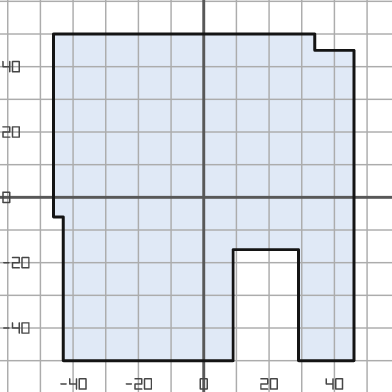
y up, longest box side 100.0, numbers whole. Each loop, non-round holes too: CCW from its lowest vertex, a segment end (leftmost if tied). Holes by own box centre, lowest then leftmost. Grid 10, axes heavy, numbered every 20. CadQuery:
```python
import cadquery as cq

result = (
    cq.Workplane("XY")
    .moveTo(-43.0, -50.0)
    .lineTo(9.0, -50.0)
    .lineTo(9.0, -16.0)
    .lineTo(29.0, -16.0)
    .lineTo(29.0, -50.0)
    .lineTo(46.0, -50.0)
    .lineTo(46.0, 45.0)
    .lineTo(34.0, 45.0)
    .lineTo(34.0, 50.0)
    .lineTo(-46.0, 50.0)
    .lineTo(-46.0, -6.0)
    .lineTo(-43.0, -6.0)
    .close()
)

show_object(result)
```